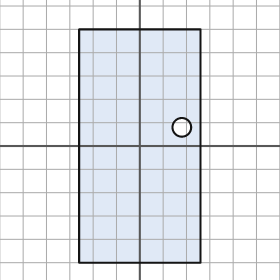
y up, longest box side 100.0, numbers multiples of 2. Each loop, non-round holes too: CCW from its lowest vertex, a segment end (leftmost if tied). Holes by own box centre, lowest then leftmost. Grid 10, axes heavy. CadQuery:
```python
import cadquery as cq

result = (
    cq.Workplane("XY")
    .moveTo(-26.0, -50.0)
    .lineTo(26.0, -50.0)
    .lineTo(26.0, 50.0)
    .lineTo(-26.0, 50.0)
    .close()
    .moveTo(18.0, 8.0)
    .circle(4.0)
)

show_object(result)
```